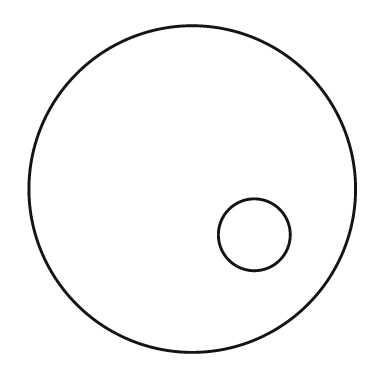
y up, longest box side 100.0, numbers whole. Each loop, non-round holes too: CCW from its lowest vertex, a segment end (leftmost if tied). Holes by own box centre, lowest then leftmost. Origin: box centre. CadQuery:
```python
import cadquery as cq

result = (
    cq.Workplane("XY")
    .moveTo(0.0, 0.0)
    .circle(50.0)
    .moveTo(19.0, -14.0)
    .circle(11.0)
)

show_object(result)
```